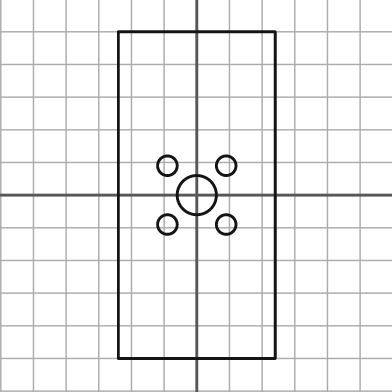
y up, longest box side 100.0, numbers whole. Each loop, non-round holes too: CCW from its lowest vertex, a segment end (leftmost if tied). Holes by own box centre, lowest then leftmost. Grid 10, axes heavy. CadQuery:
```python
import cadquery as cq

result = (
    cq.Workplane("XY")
    .moveTo(-24.0, -50.0)
    .lineTo(24.0, -50.0)
    .lineTo(24.0, 50.0)
    .lineTo(-24.0, 50.0)
    .close()
    .moveTo(-9.0, -9.0)
    .circle(3.0)
    .moveTo(9.0, -9.0)
    .circle(3.0)
    .moveTo(0.0, 0.0)
    .circle(6.0)
    .moveTo(-9.0, 9.0)
    .circle(3.0)
    .moveTo(9.0, 9.0)
    .circle(3.0)
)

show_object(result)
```